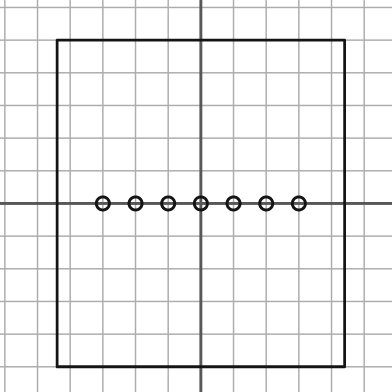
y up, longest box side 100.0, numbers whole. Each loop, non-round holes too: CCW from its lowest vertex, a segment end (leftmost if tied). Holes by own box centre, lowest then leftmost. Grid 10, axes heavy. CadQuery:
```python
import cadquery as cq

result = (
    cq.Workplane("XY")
    .moveTo(-44.0, -50.0)
    .lineTo(44.0, -50.0)
    .lineTo(44.0, 50.0)
    .lineTo(-44.0, 50.0)
    .close()
    .moveTo(-30.0, 0.0)
    .circle(2.0)
    .moveTo(-20.0, 0.0)
    .circle(2.0)
    .moveTo(-10.0, 0.0)
    .circle(2.0)
    .moveTo(0.0, 0.0)
    .circle(2.0)
    .moveTo(10.0, 0.0)
    .circle(2.0)
    .moveTo(20.0, 0.0)
    .circle(2.0)
    .moveTo(30.0, 0.0)
    .circle(2.0)
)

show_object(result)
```